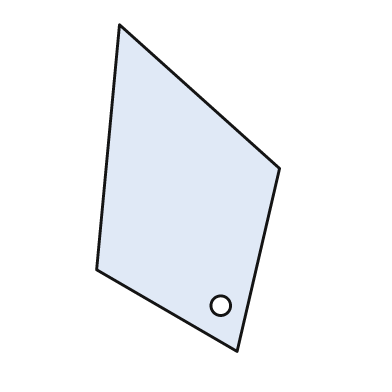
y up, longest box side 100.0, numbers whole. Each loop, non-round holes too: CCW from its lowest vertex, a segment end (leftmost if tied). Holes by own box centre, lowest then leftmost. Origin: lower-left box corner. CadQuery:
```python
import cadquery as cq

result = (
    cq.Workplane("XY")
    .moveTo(43.0, 0.0)
    .lineTo(56.0, 56.0)
    .lineTo(7.0, 100.0)
    .lineTo(0.0, 25.0)
    .close()
    .moveTo(38.0, 14.0)
    .circle(3.0)
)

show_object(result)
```